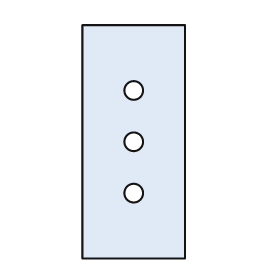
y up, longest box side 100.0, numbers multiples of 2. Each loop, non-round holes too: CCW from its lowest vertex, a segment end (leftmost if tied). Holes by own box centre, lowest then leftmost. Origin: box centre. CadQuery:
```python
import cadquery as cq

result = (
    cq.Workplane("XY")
    .moveTo(-22.0, -50.0)
    .lineTo(22.0, -50.0)
    .lineTo(22.0, 50.0)
    .lineTo(-22.0, 50.0)
    .close()
    .moveTo(0.0, -22.0)
    .circle(4.0)
    .moveTo(0.0, 0.0)
    .circle(4.0)
    .moveTo(0.0, 22.0)
    .circle(4.0)
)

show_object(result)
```